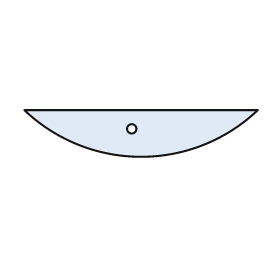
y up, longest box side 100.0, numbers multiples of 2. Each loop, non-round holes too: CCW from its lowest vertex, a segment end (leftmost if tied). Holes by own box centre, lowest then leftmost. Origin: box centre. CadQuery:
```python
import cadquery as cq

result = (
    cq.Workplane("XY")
    .moveTo(-50.0, 10.0)
    .threePointArc((0.0, -10.0), (50.0, 10.0))
    .close()
    .moveTo(-4.0, 2.0)
    .circle(2.0)
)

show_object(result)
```